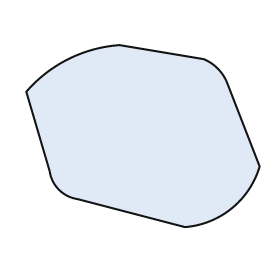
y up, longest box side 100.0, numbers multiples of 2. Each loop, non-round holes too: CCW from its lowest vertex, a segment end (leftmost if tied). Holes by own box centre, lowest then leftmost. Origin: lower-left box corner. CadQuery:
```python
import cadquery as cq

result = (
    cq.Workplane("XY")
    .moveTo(68.0, 0.0)
    .threePointArc((88.0, 8.0), (100.0, 26.0))
    .lineTo(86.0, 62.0)
    .threePointArc((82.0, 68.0), (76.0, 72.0))
    .lineTo(40.0, 78.0)
    .threePointArc((18.0, 72.0), (0.0, 58.0))
    .lineTo(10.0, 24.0)
    .threePointArc((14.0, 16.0), (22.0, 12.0))
    .close()
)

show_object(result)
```